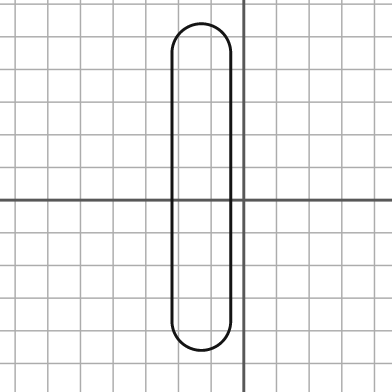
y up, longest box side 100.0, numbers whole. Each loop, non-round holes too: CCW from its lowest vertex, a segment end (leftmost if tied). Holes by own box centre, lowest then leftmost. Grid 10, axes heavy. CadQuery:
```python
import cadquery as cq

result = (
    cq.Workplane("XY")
    .moveTo(-22.0, -37.0)
    .threePointArc((-13.0, -46.0), (-4.0, -37.0))
    .lineTo(-4.0, 45.0)
    .threePointArc((-13.0, 54.0), (-22.0, 45.0))
    .close()
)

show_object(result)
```